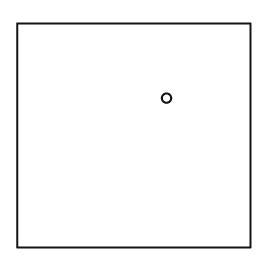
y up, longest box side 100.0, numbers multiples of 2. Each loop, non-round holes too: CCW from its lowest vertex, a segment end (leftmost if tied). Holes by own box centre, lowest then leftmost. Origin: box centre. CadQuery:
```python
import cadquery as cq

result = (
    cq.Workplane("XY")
    .moveTo(-50.0, -48.0)
    .lineTo(50.0, -48.0)
    .lineTo(50.0, 48.0)
    .lineTo(-50.0, 48.0)
    .close()
    .moveTo(14.0, 16.0)
    .circle(2.0)
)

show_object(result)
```